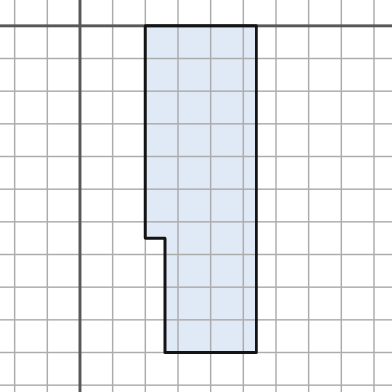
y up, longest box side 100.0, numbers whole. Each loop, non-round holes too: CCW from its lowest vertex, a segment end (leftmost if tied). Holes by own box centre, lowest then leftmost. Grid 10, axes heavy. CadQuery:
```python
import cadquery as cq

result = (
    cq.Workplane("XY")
    .moveTo(26.0, -100.0)
    .lineTo(54.0, -100.0)
    .lineTo(54.0, 0.0)
    .lineTo(20.0, 0.0)
    .lineTo(20.0, -65.0)
    .lineTo(26.0, -65.0)
    .close()
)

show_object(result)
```